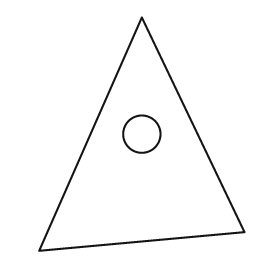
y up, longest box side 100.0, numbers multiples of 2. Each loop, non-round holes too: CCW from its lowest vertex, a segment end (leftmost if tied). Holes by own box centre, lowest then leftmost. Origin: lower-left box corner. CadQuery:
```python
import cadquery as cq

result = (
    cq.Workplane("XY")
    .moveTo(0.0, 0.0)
    .lineTo(88.0, 8.0)
    .lineTo(44.0, 100.0)
    .close()
    .moveTo(44.0, 50.0)
    .circle(8.0)
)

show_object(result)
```